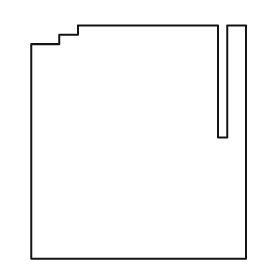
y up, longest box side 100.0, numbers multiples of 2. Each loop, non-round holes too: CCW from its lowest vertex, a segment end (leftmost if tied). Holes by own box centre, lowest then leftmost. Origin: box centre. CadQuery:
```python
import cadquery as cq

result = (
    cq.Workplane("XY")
    .moveTo(-46.0, -50.0)
    .lineTo(46.0, -50.0)
    .lineTo(46.0, 50.0)
    .lineTo(38.0, 50.0)
    .lineTo(38.0, 2.0)
    .lineTo(34.0, 2.0)
    .lineTo(34.0, 50.0)
    .lineTo(-26.0, 50.0)
    .lineTo(-26.0, 46.0)
    .lineTo(-34.0, 46.0)
    .lineTo(-34.0, 42.0)
    .lineTo(-46.0, 42.0)
    .close()
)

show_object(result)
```